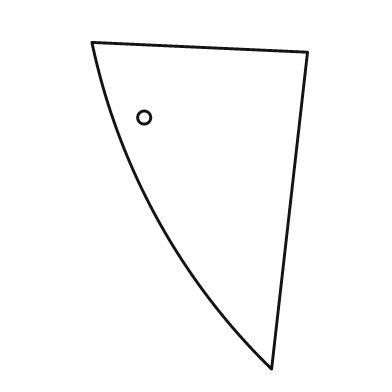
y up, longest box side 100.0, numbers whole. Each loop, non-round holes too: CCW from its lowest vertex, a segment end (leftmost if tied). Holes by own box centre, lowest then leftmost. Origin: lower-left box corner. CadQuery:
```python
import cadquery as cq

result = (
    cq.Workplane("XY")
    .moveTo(55.0, 0.0)
    .lineTo(66.0, 97.0)
    .lineTo(0.0, 100.0)
    .threePointArc((20.0, 46.0), (55.0, 0.0))
    .close()
    .moveTo(16.0, 77.0)
    .circle(2.0)
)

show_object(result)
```